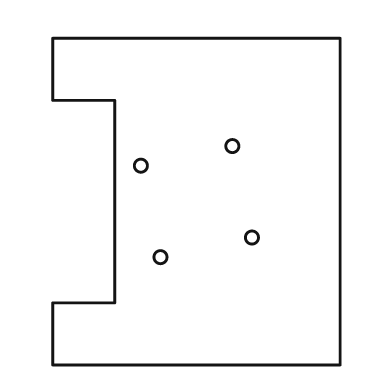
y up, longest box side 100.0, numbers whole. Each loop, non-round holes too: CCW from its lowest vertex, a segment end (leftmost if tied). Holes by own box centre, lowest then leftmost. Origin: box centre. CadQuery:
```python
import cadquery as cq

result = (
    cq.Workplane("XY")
    .moveTo(-44.0, -50.0)
    .lineTo(44.0, -50.0)
    .lineTo(44.0, 50.0)
    .lineTo(-44.0, 50.0)
    .lineTo(-44.0, 31.0)
    .lineTo(-25.0, 31.0)
    .lineTo(-25.0, -31.0)
    .lineTo(-44.0, -31.0)
    .close()
    .moveTo(-11.0, -17.0)
    .circle(2.0)
    .moveTo(17.0, -11.0)
    .circle(2.0)
    .moveTo(-17.0, 11.0)
    .circle(2.0)
    .moveTo(11.0, 17.0)
    .circle(2.0)
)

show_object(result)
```